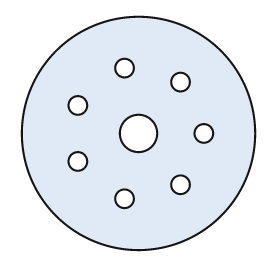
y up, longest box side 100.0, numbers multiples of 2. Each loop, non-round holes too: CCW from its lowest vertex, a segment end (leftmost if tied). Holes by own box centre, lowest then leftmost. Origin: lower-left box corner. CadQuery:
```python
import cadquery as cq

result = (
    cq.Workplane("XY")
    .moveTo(50.0, 50.0)
    .circle(50.0)
    .moveTo(44.0, 22.0)
    .circle(4.0)
    .moveTo(68.0, 28.0)
    .circle(4.0)
    .moveTo(24.0, 38.0)
    .circle(4.0)
    .moveTo(50.0, 50.0)
    .circle(8.0)
    .moveTo(78.0, 50.0)
    .circle(4.0)
    .moveTo(24.0, 62.0)
    .circle(4.0)
    .moveTo(68.0, 72.0)
    .circle(4.0)
    .moveTo(44.0, 78.0)
    .circle(4.0)
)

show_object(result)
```